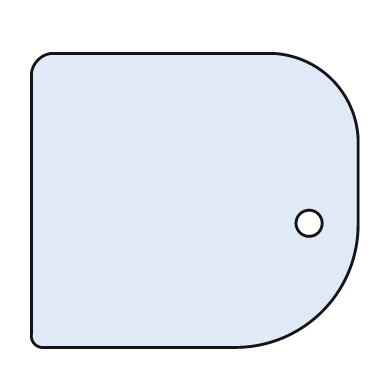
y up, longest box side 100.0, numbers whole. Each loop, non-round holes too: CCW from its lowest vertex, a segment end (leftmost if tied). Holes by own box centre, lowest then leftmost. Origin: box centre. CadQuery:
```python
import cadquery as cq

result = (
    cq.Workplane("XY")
    .moveTo(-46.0, -45.0)
    .lineTo(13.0, -45.0)
    .threePointArc((39.0, -34.0), (50.0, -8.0))
    .lineTo(50.0, 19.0)
    .threePointArc((42.0, 37.0), (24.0, 45.0))
    .lineTo(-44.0, 45.0)
    .threePointArc((-48.0, 43.0), (-50.0, 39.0))
    .lineTo(-50.0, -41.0)
    .threePointArc((-49.0, -44.0), (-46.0, -45.0))
    .close()
    .moveTo(35.0, -7.0)
    .circle(4.0)
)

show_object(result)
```